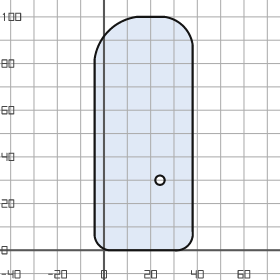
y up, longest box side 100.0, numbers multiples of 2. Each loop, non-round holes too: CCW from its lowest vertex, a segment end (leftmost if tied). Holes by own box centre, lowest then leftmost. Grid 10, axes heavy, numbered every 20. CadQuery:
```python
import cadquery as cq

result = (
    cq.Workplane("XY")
    .moveTo(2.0, 0.0)
    .lineTo(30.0, 0.0)
    .threePointArc((36.0, 2.0), (38.0, 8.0))
    .lineTo(38.0, 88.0)
    .threePointArc((34.0, 96.0), (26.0, 100.0))
    .lineTo(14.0, 100.0)
    .threePointArc((2.0, 94.0), (-4.0, 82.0))
    .lineTo(-4.0, 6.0)
    .threePointArc((-2.0, 2.0), (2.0, 0.0))
    .close()
    .moveTo(24.0, 30.0)
    .circle(2.0)
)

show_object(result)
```